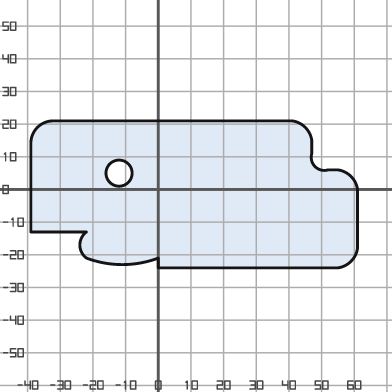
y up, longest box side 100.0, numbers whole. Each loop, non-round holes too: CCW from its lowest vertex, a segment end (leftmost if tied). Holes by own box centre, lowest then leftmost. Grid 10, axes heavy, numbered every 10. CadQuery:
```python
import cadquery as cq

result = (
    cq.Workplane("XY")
    .moveTo(0.0, -24.0)
    .lineTo(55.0, -24.0)
    .threePointArc((59.0, -22.0), (61.0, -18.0))
    .lineTo(61.0, 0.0)
    .threePointArc((59.0, 4.0), (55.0, 6.0))
    .lineTo(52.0, 6.0)
    .threePointArc((48.0, 7.0), (47.0, 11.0))
    .lineTo(47.0, 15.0)
    .threePointArc((45.0, 19.0), (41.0, 21.0))
    .lineTo(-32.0, 21.0)
    .threePointArc((-37.0, 19.0), (-39.0, 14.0))
    .lineTo(-39.0, -13.0)
    .lineTo(-22.0, -13.0)
    .threePointArc((-24.0, -17.0), (-22.0, -21.0))
    .threePointArc((-11.0, -23.0), (0.0, -21.0))
    .close()
    .moveTo(-12.0, 5.0)
    .circle(4.0)
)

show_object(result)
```